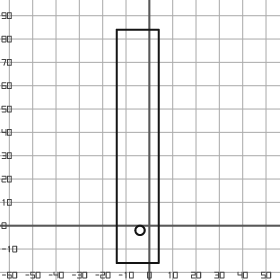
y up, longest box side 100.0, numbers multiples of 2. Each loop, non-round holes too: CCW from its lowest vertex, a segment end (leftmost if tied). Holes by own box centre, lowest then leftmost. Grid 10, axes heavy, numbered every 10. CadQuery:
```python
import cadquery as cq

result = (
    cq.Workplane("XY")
    .moveTo(-14.0, -16.0)
    .lineTo(4.0, -16.0)
    .lineTo(4.0, 84.0)
    .lineTo(-14.0, 84.0)
    .close()
    .moveTo(-4.0, -2.0)
    .circle(2.0)
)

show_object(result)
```